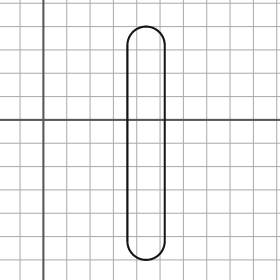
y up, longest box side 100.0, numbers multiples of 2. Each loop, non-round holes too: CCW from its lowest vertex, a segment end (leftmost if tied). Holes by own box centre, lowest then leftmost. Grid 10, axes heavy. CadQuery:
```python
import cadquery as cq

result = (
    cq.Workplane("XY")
    .moveTo(36.0, -52.0)
    .threePointArc((44.0, -60.0), (52.0, -52.0))
    .lineTo(52.0, 32.0)
    .threePointArc((44.0, 40.0), (36.0, 32.0))
    .close()
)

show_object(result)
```